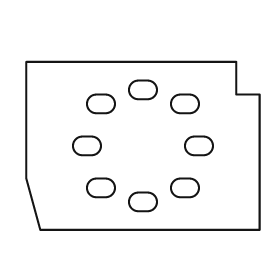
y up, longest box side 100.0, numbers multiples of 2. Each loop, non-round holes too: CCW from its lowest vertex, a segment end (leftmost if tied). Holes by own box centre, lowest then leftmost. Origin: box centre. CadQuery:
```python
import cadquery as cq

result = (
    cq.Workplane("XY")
    .moveTo(-44.0, -36.0)
    .lineTo(50.0, -36.0)
    .lineTo(50.0, 22.0)
    .lineTo(40.0, 22.0)
    .lineTo(40.0, 36.0)
    .lineTo(-50.0, 36.0)
    .lineTo(-50.0, -14.0)
    .close()
    .moveTo(-2.0, -28.0)
    .lineTo(2.0, -28.0)
    .threePointArc((6.0, -24.0), (2.0, -20.0))
    .lineTo(-2.0, -20.0)
    .threePointArc((-6.0, -24.0), (-2.0, -28.0))
    .close()
    .moveTo(-20.0, -22.0)
    .lineTo(-16.0, -22.0)
    .threePointArc((-12.0, -18.0), (-16.0, -14.0))
    .lineTo(-20.0, -14.0)
    .threePointArc((-24.0, -18.0), (-20.0, -22.0))
    .close()
    .moveTo(16.0, -22.0)
    .lineTo(20.0, -22.0)
    .threePointArc((24.0, -18.0), (20.0, -14.0))
    .lineTo(16.0, -14.0)
    .threePointArc((12.0, -18.0), (16.0, -22.0))
    .close()
    .moveTo(-26.0, -4.0)
    .lineTo(-22.0, -4.0)
    .threePointArc((-18.0, 0.0), (-22.0, 4.0))
    .lineTo(-26.0, 4.0)
    .threePointArc((-30.0, 0.0), (-26.0, -4.0))
    .close()
    .moveTo(22.0, -4.0)
    .lineTo(26.0, -4.0)
    .threePointArc((30.0, 0.0), (26.0, 4.0))
    .lineTo(22.0, 4.0)
    .threePointArc((18.0, 0.0), (22.0, -4.0))
    .close()
    .moveTo(-20.0, 14.0)
    .lineTo(-16.0, 14.0)
    .threePointArc((-12.0, 18.0), (-16.0, 22.0))
    .lineTo(-20.0, 22.0)
    .threePointArc((-24.0, 18.0), (-20.0, 14.0))
    .close()
    .moveTo(16.0, 14.0)
    .lineTo(20.0, 14.0)
    .threePointArc((24.0, 18.0), (20.0, 22.0))
    .lineTo(16.0, 22.0)
    .threePointArc((12.0, 18.0), (16.0, 14.0))
    .close()
    .moveTo(-2.0, 20.0)
    .lineTo(2.0, 20.0)
    .threePointArc((6.0, 24.0), (2.0, 28.0))
    .lineTo(-2.0, 28.0)
    .threePointArc((-6.0, 24.0), (-2.0, 20.0))
    .close()
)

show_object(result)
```